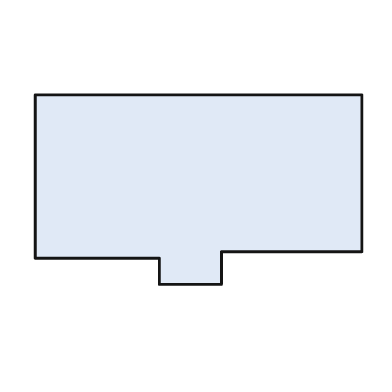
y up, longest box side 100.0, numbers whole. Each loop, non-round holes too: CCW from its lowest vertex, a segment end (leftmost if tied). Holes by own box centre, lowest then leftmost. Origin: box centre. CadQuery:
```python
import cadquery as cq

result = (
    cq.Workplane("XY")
    .moveTo(-12.0, -29.0)
    .lineTo(7.0, -29.0)
    .lineTo(7.0, -19.0)
    .lineTo(50.0, -19.0)
    .lineTo(50.0, 29.0)
    .lineTo(-50.0, 29.0)
    .lineTo(-50.0, -21.0)
    .lineTo(-12.0, -21.0)
    .close()
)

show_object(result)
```